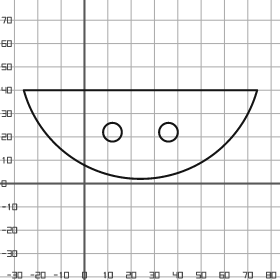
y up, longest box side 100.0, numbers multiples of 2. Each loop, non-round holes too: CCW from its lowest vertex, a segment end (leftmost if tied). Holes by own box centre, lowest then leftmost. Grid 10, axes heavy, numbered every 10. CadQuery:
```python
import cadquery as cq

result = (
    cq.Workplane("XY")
    .moveTo(-26.0, 40.0)
    .threePointArc((24.0, 2.0), (74.0, 40.0))
    .close()
    .moveTo(12.0, 22.0)
    .circle(4.0)
    .moveTo(36.0, 22.0)
    .circle(4.0)
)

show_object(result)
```